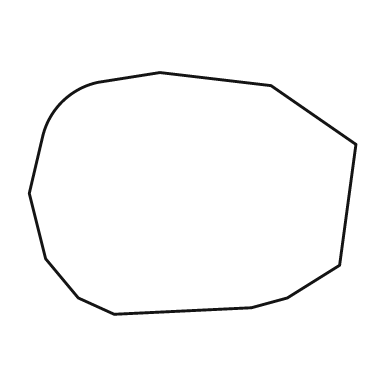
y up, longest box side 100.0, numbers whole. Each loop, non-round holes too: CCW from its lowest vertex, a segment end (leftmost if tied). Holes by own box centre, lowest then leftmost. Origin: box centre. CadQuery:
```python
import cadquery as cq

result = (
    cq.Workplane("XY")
    .moveTo(-24.0, -37.0)
    .lineTo(18.0, -35.0)
    .lineTo(29.0, -32.0)
    .lineTo(45.0, -22.0)
    .lineTo(50.0, 15.0)
    .lineTo(24.0, 33.0)
    .lineTo(-10.0, 37.0)
    .lineTo(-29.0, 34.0)
    .threePointArc((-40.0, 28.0), (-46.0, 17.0))
    .lineTo(-50.0, 0.0)
    .lineTo(-45.0, -20.0)
    .lineTo(-35.0, -32.0)
    .close()
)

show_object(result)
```